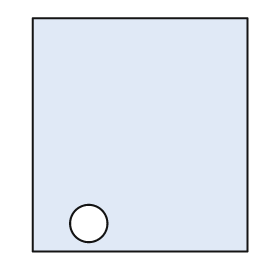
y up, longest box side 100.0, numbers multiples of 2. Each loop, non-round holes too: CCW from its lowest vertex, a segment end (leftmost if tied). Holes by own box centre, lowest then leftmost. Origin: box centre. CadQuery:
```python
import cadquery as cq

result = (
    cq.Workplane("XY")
    .moveTo(-46.0, -50.0)
    .lineTo(46.0, -50.0)
    .lineTo(46.0, 50.0)
    .lineTo(-46.0, 50.0)
    .close()
    .moveTo(-22.0, -38.0)
    .circle(8.0)
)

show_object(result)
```